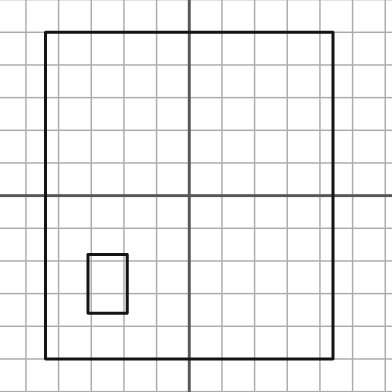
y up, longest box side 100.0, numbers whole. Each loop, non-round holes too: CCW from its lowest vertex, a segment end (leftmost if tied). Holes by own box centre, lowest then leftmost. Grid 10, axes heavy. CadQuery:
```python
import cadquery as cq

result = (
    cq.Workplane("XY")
    .moveTo(-44.0, -50.0)
    .lineTo(44.0, -50.0)
    .lineTo(44.0, 50.0)
    .lineTo(-44.0, 50.0)
    .close()
    .moveTo(-31.0, -36.0)
    .lineTo(-19.0, -36.0)
    .lineTo(-19.0, -18.0)
    .lineTo(-31.0, -18.0)
    .close()
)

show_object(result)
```